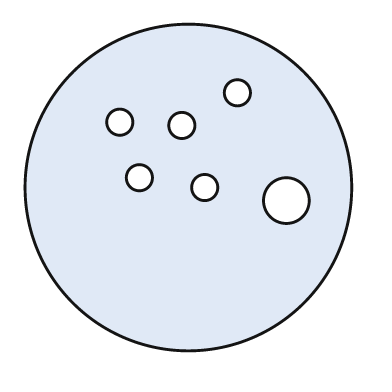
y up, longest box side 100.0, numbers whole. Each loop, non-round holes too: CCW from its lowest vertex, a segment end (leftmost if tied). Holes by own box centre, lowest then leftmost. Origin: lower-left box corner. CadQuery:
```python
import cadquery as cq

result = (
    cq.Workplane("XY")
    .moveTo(50.0, 50.0)
    .circle(50.0)
    .moveTo(80.0, 46.0)
    .circle(7.0)
    .moveTo(55.0, 50.0)
    .circle(4.0)
    .moveTo(35.0, 53.0)
    .circle(4.0)
    .moveTo(48.0, 69.0)
    .circle(4.0)
    .moveTo(29.0, 70.0)
    .circle(4.0)
    .moveTo(65.0, 79.0)
    .circle(4.0)
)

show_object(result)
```